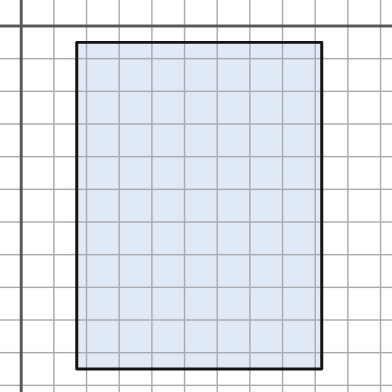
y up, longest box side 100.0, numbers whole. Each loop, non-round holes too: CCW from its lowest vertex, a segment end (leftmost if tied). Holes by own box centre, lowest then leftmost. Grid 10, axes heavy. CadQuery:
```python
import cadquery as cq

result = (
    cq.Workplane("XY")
    .moveTo(17.0, -105.0)
    .lineTo(92.0, -105.0)
    .lineTo(92.0, -5.0)
    .lineTo(17.0, -5.0)
    .close()
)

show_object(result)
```